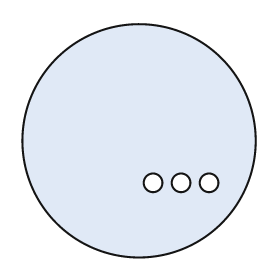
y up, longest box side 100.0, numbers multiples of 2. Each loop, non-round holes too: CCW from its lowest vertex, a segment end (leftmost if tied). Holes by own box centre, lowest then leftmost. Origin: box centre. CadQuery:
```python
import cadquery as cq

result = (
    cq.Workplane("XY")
    .moveTo(0.0, 0.0)
    .circle(50.0)
    .moveTo(6.0, -18.0)
    .circle(4.0)
    .moveTo(18.0, -18.0)
    .circle(4.0)
    .moveTo(30.0, -18.0)
    .circle(4.0)
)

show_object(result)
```